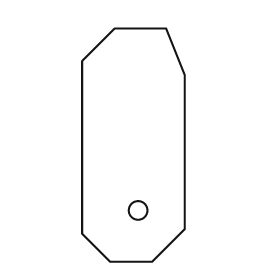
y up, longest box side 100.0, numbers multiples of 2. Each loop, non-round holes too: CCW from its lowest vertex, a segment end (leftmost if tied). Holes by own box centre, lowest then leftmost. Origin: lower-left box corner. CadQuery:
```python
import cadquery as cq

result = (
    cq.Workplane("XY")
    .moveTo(12.0, 0.0)
    .lineTo(30.0, 0.0)
    .lineTo(44.0, 14.0)
    .lineTo(44.0, 80.0)
    .lineTo(36.0, 100.0)
    .lineTo(14.0, 100.0)
    .lineTo(0.0, 86.0)
    .lineTo(0.0, 12.0)
    .close()
    .moveTo(24.0, 22.0)
    .circle(4.0)
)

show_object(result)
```